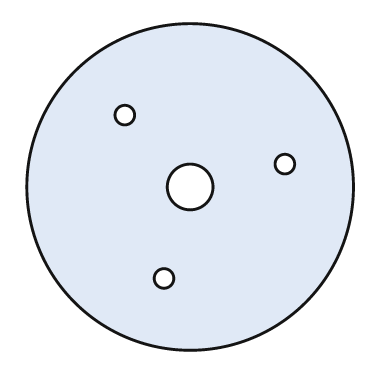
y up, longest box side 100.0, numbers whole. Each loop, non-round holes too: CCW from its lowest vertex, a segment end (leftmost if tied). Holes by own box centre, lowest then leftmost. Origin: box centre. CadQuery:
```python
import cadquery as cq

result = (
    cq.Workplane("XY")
    .moveTo(0.0, 0.0)
    .circle(50.0)
    .moveTo(-8.0, -28.0)
    .circle(3.0)
    .moveTo(0.0, 0.0)
    .circle(7.0)
    .moveTo(29.0, 7.0)
    .circle(3.0)
    .moveTo(-20.0, 22.0)
    .circle(3.0)
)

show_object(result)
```